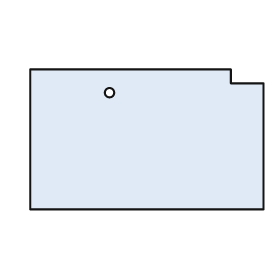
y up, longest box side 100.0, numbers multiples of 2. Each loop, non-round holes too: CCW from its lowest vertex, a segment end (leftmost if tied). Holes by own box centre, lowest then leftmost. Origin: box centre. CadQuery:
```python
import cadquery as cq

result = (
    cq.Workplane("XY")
    .moveTo(-50.0, -30.0)
    .lineTo(50.0, -30.0)
    .lineTo(50.0, 24.0)
    .lineTo(36.0, 24.0)
    .lineTo(36.0, 30.0)
    .lineTo(-50.0, 30.0)
    .close()
    .moveTo(-16.0, 20.0)
    .circle(2.0)
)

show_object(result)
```